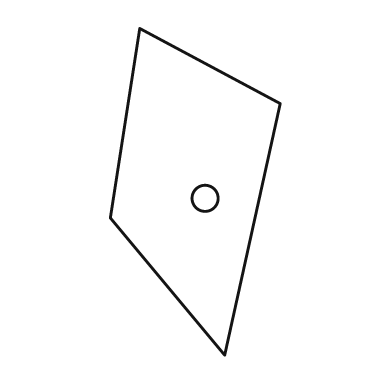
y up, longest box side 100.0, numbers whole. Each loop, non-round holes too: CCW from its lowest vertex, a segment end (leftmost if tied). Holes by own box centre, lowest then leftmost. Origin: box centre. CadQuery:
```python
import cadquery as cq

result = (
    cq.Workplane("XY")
    .moveTo(9.0, -50.0)
    .lineTo(26.0, 27.0)
    .lineTo(-17.0, 50.0)
    .lineTo(-26.0, -8.0)
    .close()
    .moveTo(3.0, -2.0)
    .circle(4.0)
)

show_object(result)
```